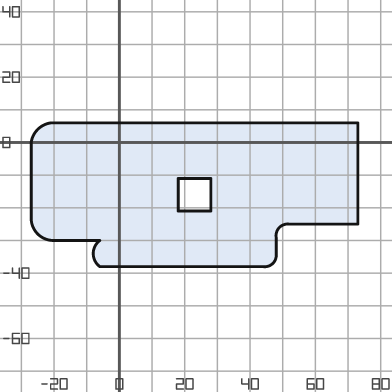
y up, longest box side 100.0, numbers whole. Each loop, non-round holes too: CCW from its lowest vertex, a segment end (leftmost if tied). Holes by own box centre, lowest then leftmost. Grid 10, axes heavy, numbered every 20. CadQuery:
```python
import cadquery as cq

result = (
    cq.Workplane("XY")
    .moveTo(-6.0, -38.0)
    .lineTo(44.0, -38.0)
    .threePointArc((47.0, -37.0), (48.0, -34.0))
    .lineTo(48.0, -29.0)
    .threePointArc((49.0, -26.0), (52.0, -25.0))
    .lineTo(73.0, -25.0)
    .lineTo(73.0, 6.0)
    .lineTo(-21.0, 6.0)
    .threePointArc((-25.0, 4.0), (-27.0, 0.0))
    .lineTo(-27.0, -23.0)
    .threePointArc((-25.0, -28.0), (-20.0, -30.0))
    .lineTo(-6.0, -30.0)
    .threePointArc((-8.0, -34.0), (-6.0, -38.0))
    .close()
    .moveTo(18.0, -21.0)
    .lineTo(28.0, -21.0)
    .lineTo(28.0, -11.0)
    .lineTo(18.0, -11.0)
    .close()
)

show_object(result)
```